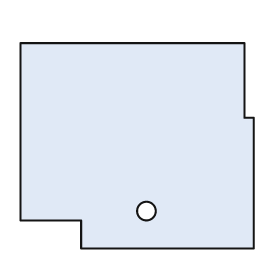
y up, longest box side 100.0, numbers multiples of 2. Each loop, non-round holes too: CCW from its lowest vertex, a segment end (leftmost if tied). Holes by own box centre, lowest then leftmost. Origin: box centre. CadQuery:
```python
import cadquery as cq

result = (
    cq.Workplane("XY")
    .moveTo(-24.0, -44.0)
    .lineTo(50.0, -44.0)
    .lineTo(50.0, 12.0)
    .lineTo(46.0, 12.0)
    .lineTo(46.0, 44.0)
    .lineTo(-50.0, 44.0)
    .lineTo(-50.0, -32.0)
    .lineTo(-24.0, -32.0)
    .close()
    .moveTo(4.0, -28.0)
    .circle(4.0)
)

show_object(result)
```